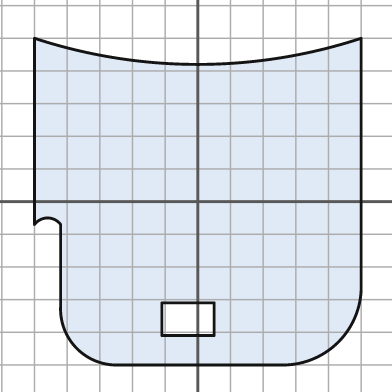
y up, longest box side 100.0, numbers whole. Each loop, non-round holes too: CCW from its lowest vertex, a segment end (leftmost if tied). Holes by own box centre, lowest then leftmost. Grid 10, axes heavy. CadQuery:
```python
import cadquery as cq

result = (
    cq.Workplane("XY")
    .moveTo(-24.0, -50.0)
    .lineTo(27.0, -50.0)
    .threePointArc((43.0, -43.0), (50.0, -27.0))
    .lineTo(50.0, 50.0)
    .threePointArc((0.0, 42.0), (-50.0, 50.0))
    .lineTo(-50.0, -7.0)
    .threePointArc((-46.0, -5.0), (-42.0, -7.0))
    .lineTo(-42.0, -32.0)
    .threePointArc((-37.0, -45.0), (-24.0, -50.0))
    .close()
    .moveTo(-11.0, -41.0)
    .lineTo(5.0, -41.0)
    .lineTo(5.0, -31.0)
    .lineTo(-11.0, -31.0)
    .close()
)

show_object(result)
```